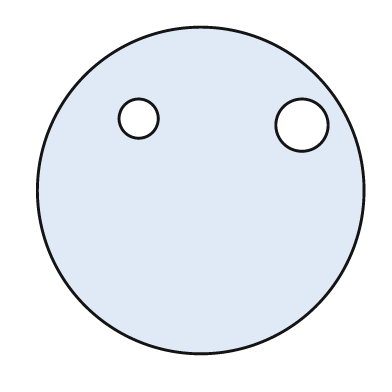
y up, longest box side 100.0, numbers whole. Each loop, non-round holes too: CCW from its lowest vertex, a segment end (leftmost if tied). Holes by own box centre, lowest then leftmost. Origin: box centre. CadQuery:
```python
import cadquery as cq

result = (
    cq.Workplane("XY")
    .moveTo(0.0, 0.0)
    .circle(50.0)
    .moveTo(31.0, 20.0)
    .circle(8.0)
    .moveTo(-19.0, 22.0)
    .circle(6.0)
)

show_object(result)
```